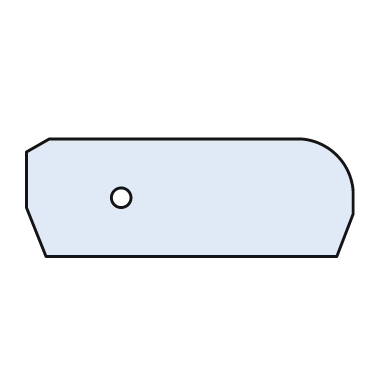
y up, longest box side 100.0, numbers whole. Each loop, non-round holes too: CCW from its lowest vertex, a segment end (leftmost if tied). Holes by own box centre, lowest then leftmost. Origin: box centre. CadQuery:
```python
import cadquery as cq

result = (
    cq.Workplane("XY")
    .moveTo(-44.0, -18.0)
    .lineTo(45.0, -18.0)
    .lineTo(50.0, -5.0)
    .lineTo(50.0, 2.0)
    .threePointArc((45.0, 13.0), (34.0, 18.0))
    .lineTo(-43.0, 18.0)
    .lineTo(-50.0, 14.0)
    .lineTo(-50.0, -3.0)
    .close()
    .moveTo(-21.0, 0.0)
    .circle(3.0)
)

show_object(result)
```